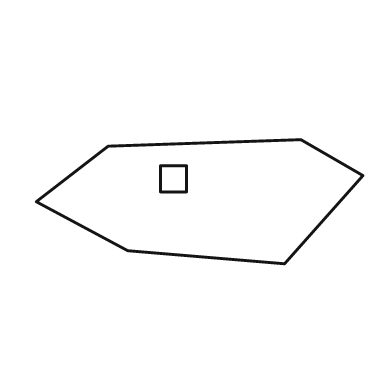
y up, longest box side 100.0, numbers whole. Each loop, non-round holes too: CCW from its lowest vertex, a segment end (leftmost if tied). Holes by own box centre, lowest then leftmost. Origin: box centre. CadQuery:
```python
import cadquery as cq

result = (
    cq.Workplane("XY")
    .moveTo(26.0, -19.0)
    .lineTo(50.0, 8.0)
    .lineTo(31.0, 19.0)
    .lineTo(-28.0, 17.0)
    .lineTo(-50.0, 0.0)
    .lineTo(-22.0, -15.0)
    .close()
    .moveTo(-12.0, 3.0)
    .lineTo(-4.0, 3.0)
    .lineTo(-4.0, 11.0)
    .lineTo(-12.0, 11.0)
    .close()
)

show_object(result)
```